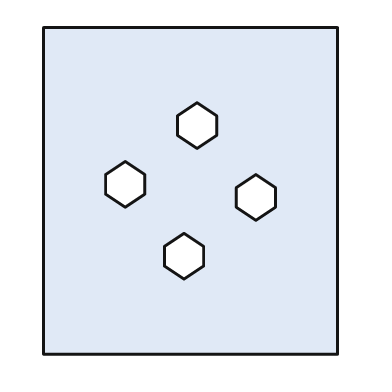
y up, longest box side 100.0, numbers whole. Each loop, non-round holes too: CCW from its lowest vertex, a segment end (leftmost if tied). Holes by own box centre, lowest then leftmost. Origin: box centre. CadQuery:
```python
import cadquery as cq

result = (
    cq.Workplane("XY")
    .moveTo(-45.0, -50.0)
    .lineTo(45.0, -50.0)
    .lineTo(45.0, 50.0)
    .lineTo(-45.0, 50.0)
    .close()
    .moveTo(-2.0, -27.0)
    .lineTo(4.0, -23.0)
    .lineTo(4.0, -17.0)
    .lineTo(-2.0, -13.0)
    .lineTo(-8.0, -17.0)
    .lineTo(-8.0, -23.0)
    .close()
    .moveTo(20.0, -9.0)
    .lineTo(26.0, -5.0)
    .lineTo(26.0, 1.0)
    .lineTo(20.0, 5.0)
    .lineTo(14.0, 1.0)
    .lineTo(14.0, -5.0)
    .close()
    .moveTo(-20.0, -5.0)
    .lineTo(-14.0, -1.0)
    .lineTo(-14.0, 5.0)
    .lineTo(-20.0, 9.0)
    .lineTo(-26.0, 5.0)
    .lineTo(-26.0, -1.0)
    .close()
    .moveTo(2.0, 13.0)
    .lineTo(8.0, 17.0)
    .lineTo(8.0, 23.0)
    .lineTo(2.0, 27.0)
    .lineTo(-4.0, 23.0)
    .lineTo(-4.0, 17.0)
    .close()
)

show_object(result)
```